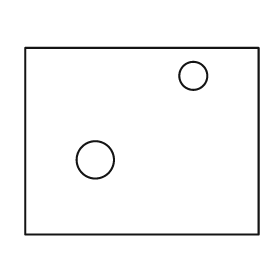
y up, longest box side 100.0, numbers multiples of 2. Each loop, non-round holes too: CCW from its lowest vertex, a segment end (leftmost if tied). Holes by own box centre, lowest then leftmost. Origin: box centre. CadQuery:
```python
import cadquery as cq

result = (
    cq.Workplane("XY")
    .moveTo(-50.0, -40.0)
    .lineTo(50.0, -40.0)
    .lineTo(50.0, 40.0)
    .lineTo(-50.0, 40.0)
    .close()
    .moveTo(-20.0, -8.0)
    .circle(8.0)
    .moveTo(22.0, 28.0)
    .circle(6.0)
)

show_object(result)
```